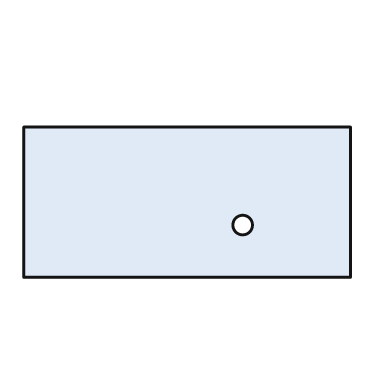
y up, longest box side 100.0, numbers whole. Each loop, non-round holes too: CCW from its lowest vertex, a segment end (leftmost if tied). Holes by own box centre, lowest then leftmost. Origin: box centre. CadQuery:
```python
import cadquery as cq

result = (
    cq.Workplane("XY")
    .moveTo(-50.0, -23.0)
    .lineTo(50.0, -23.0)
    .lineTo(50.0, 23.0)
    .lineTo(-50.0, 23.0)
    .close()
    .moveTo(17.0, -7.0)
    .circle(3.0)
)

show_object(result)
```